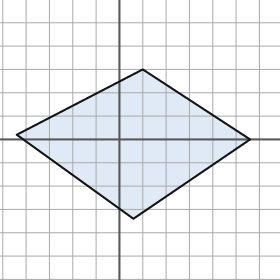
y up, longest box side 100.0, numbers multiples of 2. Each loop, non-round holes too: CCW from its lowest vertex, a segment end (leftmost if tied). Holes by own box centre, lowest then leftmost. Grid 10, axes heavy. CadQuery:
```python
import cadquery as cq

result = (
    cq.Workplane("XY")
    .moveTo(6.0, -34.0)
    .lineTo(56.0, 0.0)
    .lineTo(10.0, 30.0)
    .lineTo(-44.0, 2.0)
    .close()
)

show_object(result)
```